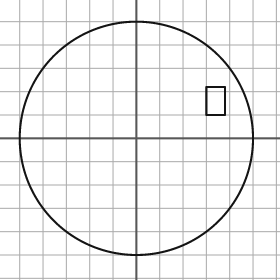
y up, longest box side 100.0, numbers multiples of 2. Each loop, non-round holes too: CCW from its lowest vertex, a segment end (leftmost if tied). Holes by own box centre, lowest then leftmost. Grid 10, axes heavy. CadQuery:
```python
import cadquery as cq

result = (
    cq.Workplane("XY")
    .moveTo(0.0, 0.0)
    .circle(50.0)
    .moveTo(30.0, 10.0)
    .lineTo(38.0, 10.0)
    .lineTo(38.0, 22.0)
    .lineTo(30.0, 22.0)
    .close()
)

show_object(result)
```